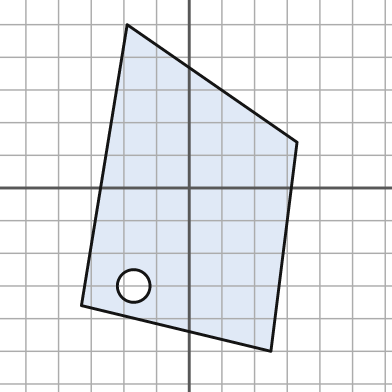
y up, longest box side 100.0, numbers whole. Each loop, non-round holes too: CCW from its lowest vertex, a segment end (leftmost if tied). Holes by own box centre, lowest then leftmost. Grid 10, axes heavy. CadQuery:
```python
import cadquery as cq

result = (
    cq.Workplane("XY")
    .moveTo(25.0, -50.0)
    .lineTo(33.0, 14.0)
    .lineTo(-19.0, 50.0)
    .lineTo(-33.0, -36.0)
    .close()
    .moveTo(-17.0, -30.0)
    .circle(5.0)
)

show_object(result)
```